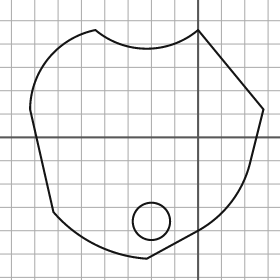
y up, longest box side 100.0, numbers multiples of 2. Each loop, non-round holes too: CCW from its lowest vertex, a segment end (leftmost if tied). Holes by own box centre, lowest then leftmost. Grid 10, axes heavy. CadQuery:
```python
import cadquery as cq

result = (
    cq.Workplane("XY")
    .moveTo(-22.0, -52.0)
    .lineTo(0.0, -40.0)
    .threePointArc((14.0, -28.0), (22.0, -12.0))
    .lineTo(28.0, 12.0)
    .lineTo(0.0, 46.0)
    .threePointArc((-22.0, 38.0), (-44.0, 46.0))
    .threePointArc((-64.0, 34.0), (-72.0, 12.0))
    .lineTo(-62.0, -32.0)
    .threePointArc((-44.0, -46.0), (-22.0, -52.0))
    .close()
    .moveTo(-20.0, -36.0)
    .circle(8.0)
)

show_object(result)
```